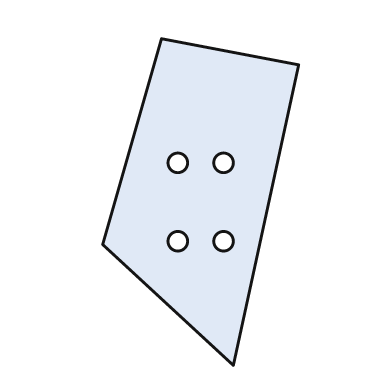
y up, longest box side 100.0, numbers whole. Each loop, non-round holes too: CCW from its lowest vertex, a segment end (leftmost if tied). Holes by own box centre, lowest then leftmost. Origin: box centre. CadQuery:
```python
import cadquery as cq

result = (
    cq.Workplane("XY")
    .moveTo(10.0, -50.0)
    .lineTo(30.0, 42.0)
    .lineTo(-12.0, 50.0)
    .lineTo(-30.0, -13.0)
    .close()
    .moveTo(-7.0, -12.0)
    .circle(3.0)
    .moveTo(7.0, -12.0)
    .circle(3.0)
    .moveTo(-7.0, 12.0)
    .circle(3.0)
    .moveTo(7.0, 12.0)
    .circle(3.0)
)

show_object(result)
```